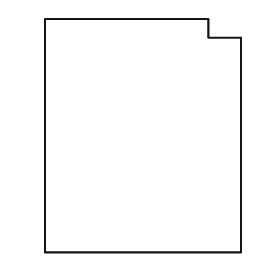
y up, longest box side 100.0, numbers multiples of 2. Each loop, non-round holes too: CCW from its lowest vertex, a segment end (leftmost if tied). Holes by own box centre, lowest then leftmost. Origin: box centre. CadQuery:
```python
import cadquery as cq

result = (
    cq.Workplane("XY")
    .moveTo(-42.0, -50.0)
    .lineTo(42.0, -50.0)
    .lineTo(42.0, 42.0)
    .lineTo(28.0, 42.0)
    .lineTo(28.0, 50.0)
    .lineTo(-42.0, 50.0)
    .close()
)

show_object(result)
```